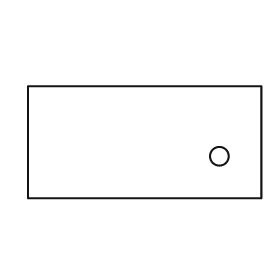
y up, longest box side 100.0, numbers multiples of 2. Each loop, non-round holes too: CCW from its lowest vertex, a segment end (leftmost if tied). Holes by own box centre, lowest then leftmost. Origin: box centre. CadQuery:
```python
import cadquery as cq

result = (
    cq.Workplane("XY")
    .moveTo(-50.0, -24.0)
    .lineTo(50.0, -24.0)
    .lineTo(50.0, 24.0)
    .lineTo(-50.0, 24.0)
    .close()
    .moveTo(32.0, -6.0)
    .circle(4.0)
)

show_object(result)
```